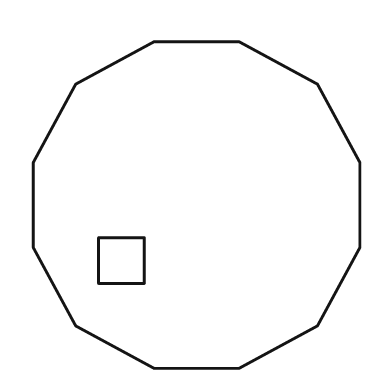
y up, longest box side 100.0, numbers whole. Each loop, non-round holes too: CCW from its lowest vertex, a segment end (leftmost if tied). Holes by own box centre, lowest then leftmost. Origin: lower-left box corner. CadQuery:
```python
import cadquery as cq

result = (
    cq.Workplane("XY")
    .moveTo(37.0, 0.0)
    .lineTo(63.0, 0.0)
    .lineTo(87.0, 13.0)
    .lineTo(100.0, 37.0)
    .lineTo(100.0, 63.0)
    .lineTo(87.0, 87.0)
    .lineTo(63.0, 100.0)
    .lineTo(37.0, 100.0)
    .lineTo(13.0, 87.0)
    .lineTo(0.0, 63.0)
    .lineTo(0.0, 37.0)
    .lineTo(13.0, 13.0)
    .close()
    .moveTo(20.0, 26.0)
    .lineTo(34.0, 26.0)
    .lineTo(34.0, 40.0)
    .lineTo(20.0, 40.0)
    .close()
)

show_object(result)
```